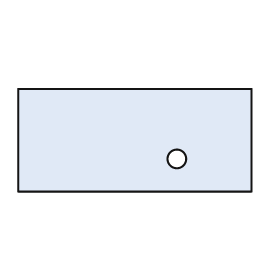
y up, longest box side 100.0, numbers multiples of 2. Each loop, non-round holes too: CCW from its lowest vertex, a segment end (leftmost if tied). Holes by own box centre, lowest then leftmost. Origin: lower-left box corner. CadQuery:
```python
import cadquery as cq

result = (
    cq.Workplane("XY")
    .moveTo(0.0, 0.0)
    .lineTo(100.0, 0.0)
    .lineTo(100.0, 44.0)
    .lineTo(0.0, 44.0)
    .close()
    .moveTo(68.0, 14.0)
    .circle(4.0)
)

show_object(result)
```